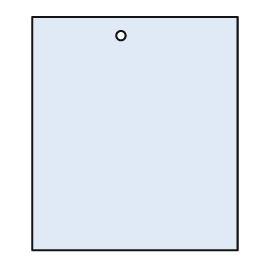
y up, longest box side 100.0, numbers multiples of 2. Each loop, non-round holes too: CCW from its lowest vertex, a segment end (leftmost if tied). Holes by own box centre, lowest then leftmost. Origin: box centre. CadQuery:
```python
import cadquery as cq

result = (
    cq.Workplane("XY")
    .moveTo(-44.0, -50.0)
    .lineTo(44.0, -50.0)
    .lineTo(44.0, 50.0)
    .lineTo(-44.0, 50.0)
    .close()
    .moveTo(-6.0, 42.0)
    .circle(2.0)
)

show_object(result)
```